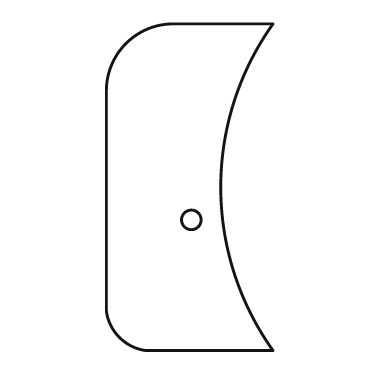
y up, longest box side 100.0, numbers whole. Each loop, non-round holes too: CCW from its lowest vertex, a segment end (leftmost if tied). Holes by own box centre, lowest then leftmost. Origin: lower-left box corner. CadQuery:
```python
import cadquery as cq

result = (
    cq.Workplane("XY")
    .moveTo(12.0, 0.0)
    .lineTo(51.0, 0.0)
    .threePointArc((35.0, 50.0), (51.0, 100.0))
    .lineTo(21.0, 100.0)
    .threePointArc((6.0, 94.0), (0.0, 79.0))
    .lineTo(0.0, 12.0)
    .threePointArc((4.0, 4.0), (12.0, 0.0))
    .close()
    .moveTo(26.0, 40.0)
    .circle(3.0)
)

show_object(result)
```